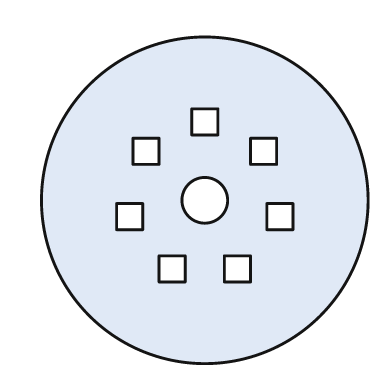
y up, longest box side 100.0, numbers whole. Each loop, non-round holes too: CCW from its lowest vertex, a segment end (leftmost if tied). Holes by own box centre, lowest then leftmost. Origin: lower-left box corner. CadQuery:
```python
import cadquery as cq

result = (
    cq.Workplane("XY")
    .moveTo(50.0, 50.0)
    .circle(50.0)
    .moveTo(36.0, 25.0)
    .lineTo(44.0, 25.0)
    .lineTo(44.0, 33.0)
    .lineTo(36.0, 33.0)
    .close()
    .moveTo(56.0, 25.0)
    .lineTo(64.0, 25.0)
    .lineTo(64.0, 33.0)
    .lineTo(56.0, 33.0)
    .close()
    .moveTo(23.0, 41.0)
    .lineTo(31.0, 41.0)
    .lineTo(31.0, 49.0)
    .lineTo(23.0, 49.0)
    .close()
    .moveTo(69.0, 41.0)
    .lineTo(77.0, 41.0)
    .lineTo(77.0, 49.0)
    .lineTo(69.0, 49.0)
    .close()
    .moveTo(50.0, 50.0)
    .circle(7.0)
    .moveTo(28.0, 61.0)
    .lineTo(36.0, 61.0)
    .lineTo(36.0, 69.0)
    .lineTo(28.0, 69.0)
    .close()
    .moveTo(64.0, 61.0)
    .lineTo(72.0, 61.0)
    .lineTo(72.0, 69.0)
    .lineTo(64.0, 69.0)
    .close()
    .moveTo(46.0, 70.0)
    .lineTo(54.0, 70.0)
    .lineTo(54.0, 78.0)
    .lineTo(46.0, 78.0)
    .close()
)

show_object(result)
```